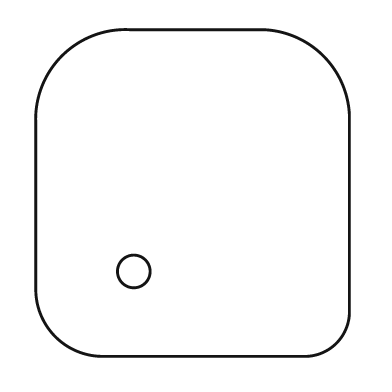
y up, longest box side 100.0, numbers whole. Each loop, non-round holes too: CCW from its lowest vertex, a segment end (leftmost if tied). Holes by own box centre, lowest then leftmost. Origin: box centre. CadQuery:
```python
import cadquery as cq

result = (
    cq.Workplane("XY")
    .moveTo(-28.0, -50.0)
    .lineTo(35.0, -50.0)
    .threePointArc((44.0, -46.0), (48.0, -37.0))
    .lineTo(48.0, 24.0)
    .threePointArc((40.0, 42.0), (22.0, 50.0))
    .lineTo(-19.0, 50.0)
    .threePointArc((-40.0, 42.0), (-48.0, 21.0))
    .lineTo(-48.0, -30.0)
    .threePointArc((-42.0, -44.0), (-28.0, -50.0))
    .close()
    .moveTo(-18.0, -24.0)
    .circle(5.0)
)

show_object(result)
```